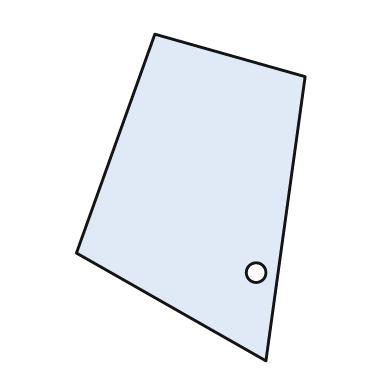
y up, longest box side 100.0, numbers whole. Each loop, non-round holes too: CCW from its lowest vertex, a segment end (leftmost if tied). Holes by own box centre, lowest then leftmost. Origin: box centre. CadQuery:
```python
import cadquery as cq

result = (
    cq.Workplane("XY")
    .moveTo(23.0, -50.0)
    .lineTo(35.0, 37.0)
    .lineTo(-11.0, 50.0)
    .lineTo(-35.0, -17.0)
    .close()
    .moveTo(20.0, -23.0)
    .circle(3.0)
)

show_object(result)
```